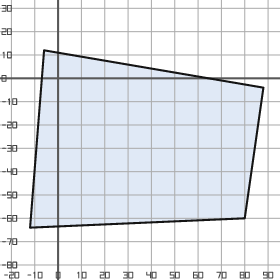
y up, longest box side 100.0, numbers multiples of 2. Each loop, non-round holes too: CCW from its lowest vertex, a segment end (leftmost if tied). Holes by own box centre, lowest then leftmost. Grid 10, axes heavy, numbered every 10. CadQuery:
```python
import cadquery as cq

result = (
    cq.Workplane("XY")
    .moveTo(-12.0, -64.0)
    .lineTo(80.0, -60.0)
    .lineTo(88.0, -4.0)
    .lineTo(-6.0, 12.0)
    .close()
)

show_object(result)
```